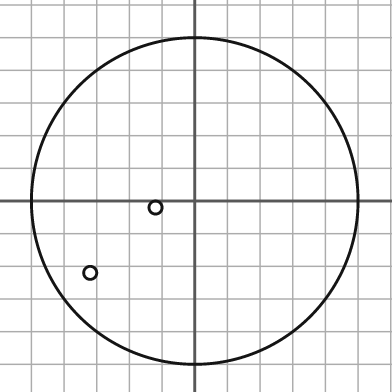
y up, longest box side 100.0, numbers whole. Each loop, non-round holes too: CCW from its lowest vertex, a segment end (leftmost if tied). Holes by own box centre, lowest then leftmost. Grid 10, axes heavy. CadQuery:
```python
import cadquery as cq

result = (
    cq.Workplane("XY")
    .moveTo(0.0, 0.0)
    .circle(50.0)
    .moveTo(-32.0, -22.0)
    .circle(2.0)
    .moveTo(-12.0, -2.0)
    .circle(2.0)
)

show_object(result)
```